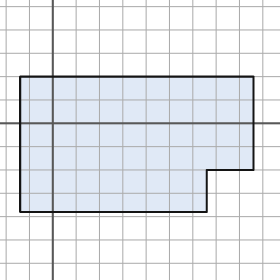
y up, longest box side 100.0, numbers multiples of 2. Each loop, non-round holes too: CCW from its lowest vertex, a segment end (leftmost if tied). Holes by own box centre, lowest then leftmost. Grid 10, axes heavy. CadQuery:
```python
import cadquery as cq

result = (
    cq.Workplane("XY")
    .moveTo(-14.0, -38.0)
    .lineTo(66.0, -38.0)
    .lineTo(66.0, -20.0)
    .lineTo(86.0, -20.0)
    .lineTo(86.0, 20.0)
    .lineTo(-14.0, 20.0)
    .close()
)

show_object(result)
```